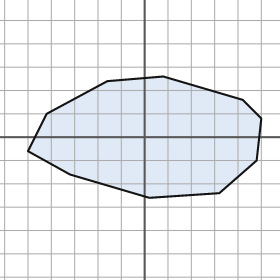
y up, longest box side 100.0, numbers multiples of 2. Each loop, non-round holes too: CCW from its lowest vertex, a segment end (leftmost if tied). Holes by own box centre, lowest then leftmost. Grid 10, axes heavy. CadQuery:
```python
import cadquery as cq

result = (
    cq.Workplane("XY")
    .moveTo(2.0, -26.0)
    .lineTo(32.0, -24.0)
    .lineTo(48.0, -10.0)
    .lineTo(50.0, 8.0)
    .lineTo(42.0, 16.0)
    .lineTo(8.0, 26.0)
    .lineTo(-16.0, 24.0)
    .lineTo(-42.0, 10.0)
    .lineTo(-50.0, -6.0)
    .lineTo(-32.0, -16.0)
    .close()
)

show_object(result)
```